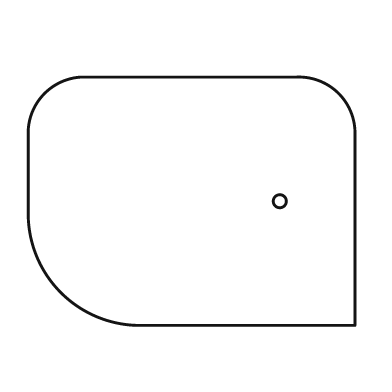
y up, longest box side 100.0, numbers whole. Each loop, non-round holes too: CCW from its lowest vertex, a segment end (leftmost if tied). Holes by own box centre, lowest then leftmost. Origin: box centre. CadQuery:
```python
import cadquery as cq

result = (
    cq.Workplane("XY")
    .moveTo(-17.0, -38.0)
    .lineTo(50.0, -38.0)
    .lineTo(50.0, 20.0)
    .threePointArc((45.0, 33.0), (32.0, 38.0))
    .lineTo(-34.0, 38.0)
    .threePointArc((-45.0, 33.0), (-50.0, 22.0))
    .lineTo(-50.0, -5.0)
    .threePointArc((-40.0, -28.0), (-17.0, -38.0))
    .close()
    .moveTo(27.0, 0.0)
    .circle(2.0)
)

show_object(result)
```